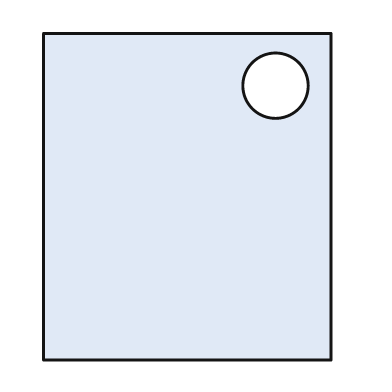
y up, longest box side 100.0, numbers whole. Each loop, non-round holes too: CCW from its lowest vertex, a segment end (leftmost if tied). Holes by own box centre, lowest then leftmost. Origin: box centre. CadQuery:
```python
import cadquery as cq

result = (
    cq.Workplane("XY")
    .moveTo(-44.0, -50.0)
    .lineTo(44.0, -50.0)
    .lineTo(44.0, 50.0)
    .lineTo(-44.0, 50.0)
    .close()
    .moveTo(27.0, 34.0)
    .circle(10.0)
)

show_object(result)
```